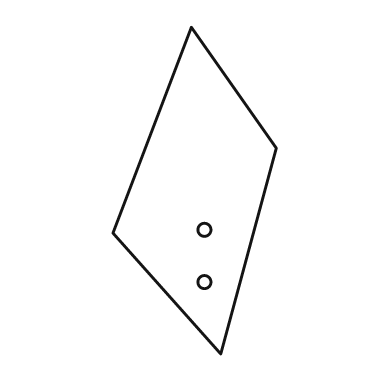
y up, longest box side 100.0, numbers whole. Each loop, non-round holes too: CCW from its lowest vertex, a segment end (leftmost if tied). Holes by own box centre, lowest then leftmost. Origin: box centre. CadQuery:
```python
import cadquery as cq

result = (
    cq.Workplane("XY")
    .moveTo(8.0, -50.0)
    .lineTo(25.0, 13.0)
    .lineTo(-1.0, 50.0)
    .lineTo(-25.0, -13.0)
    .close()
    .moveTo(3.0, -28.0)
    .circle(2.0)
    .moveTo(3.0, -12.0)
    .circle(2.0)
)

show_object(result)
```